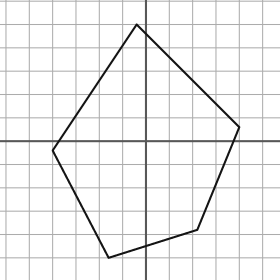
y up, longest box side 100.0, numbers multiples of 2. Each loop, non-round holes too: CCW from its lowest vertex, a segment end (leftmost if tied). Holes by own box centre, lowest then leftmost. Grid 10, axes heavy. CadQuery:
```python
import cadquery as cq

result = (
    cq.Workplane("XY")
    .moveTo(-16.0, -50.0)
    .lineTo(22.0, -38.0)
    .lineTo(40.0, 6.0)
    .lineTo(-4.0, 50.0)
    .lineTo(-40.0, -4.0)
    .close()
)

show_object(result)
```